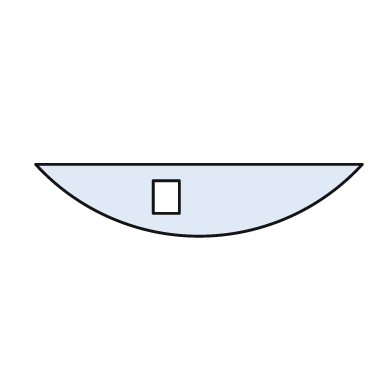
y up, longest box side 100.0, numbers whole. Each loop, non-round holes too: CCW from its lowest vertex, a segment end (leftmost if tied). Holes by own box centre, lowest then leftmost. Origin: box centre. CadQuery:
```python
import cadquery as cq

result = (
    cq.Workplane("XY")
    .moveTo(-50.0, 11.0)
    .threePointArc((0.0, -11.0), (50.0, 11.0))
    .close()
    .moveTo(-14.0, -4.0)
    .lineTo(-6.0, -4.0)
    .lineTo(-6.0, 6.0)
    .lineTo(-14.0, 6.0)
    .close()
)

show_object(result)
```